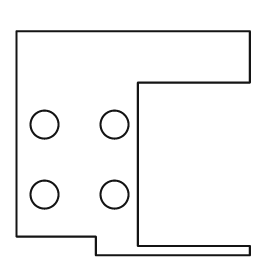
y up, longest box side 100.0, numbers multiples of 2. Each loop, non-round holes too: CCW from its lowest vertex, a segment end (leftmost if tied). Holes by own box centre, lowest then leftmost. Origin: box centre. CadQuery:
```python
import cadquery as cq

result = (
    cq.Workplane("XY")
    .moveTo(-16.0, -48.0)
    .lineTo(50.0, -48.0)
    .lineTo(50.0, -44.0)
    .lineTo(2.0, -44.0)
    .lineTo(2.0, 26.0)
    .lineTo(50.0, 26.0)
    .lineTo(50.0, 48.0)
    .lineTo(-50.0, 48.0)
    .lineTo(-50.0, -40.0)
    .lineTo(-16.0, -40.0)
    .close()
    .moveTo(-38.0, -22.0)
    .circle(6.0)
    .moveTo(-8.0, -22.0)
    .circle(6.0)
    .moveTo(-38.0, 8.0)
    .circle(6.0)
    .moveTo(-8.0, 8.0)
    .circle(6.0)
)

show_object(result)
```